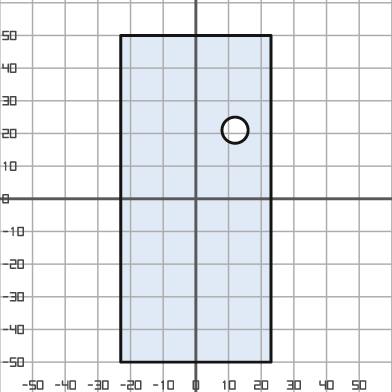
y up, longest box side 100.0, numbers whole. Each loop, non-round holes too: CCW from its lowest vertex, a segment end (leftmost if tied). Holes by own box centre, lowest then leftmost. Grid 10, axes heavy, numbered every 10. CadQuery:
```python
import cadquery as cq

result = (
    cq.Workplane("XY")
    .moveTo(-23.0, -50.0)
    .lineTo(23.0, -50.0)
    .lineTo(23.0, 50.0)
    .lineTo(-23.0, 50.0)
    .close()
    .moveTo(12.0, 21.0)
    .circle(4.0)
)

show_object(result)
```